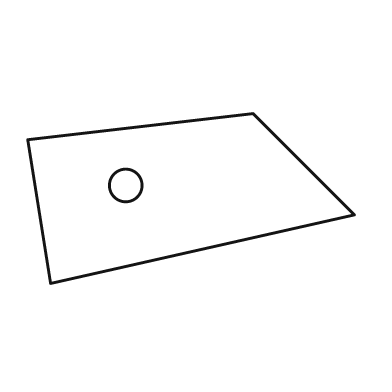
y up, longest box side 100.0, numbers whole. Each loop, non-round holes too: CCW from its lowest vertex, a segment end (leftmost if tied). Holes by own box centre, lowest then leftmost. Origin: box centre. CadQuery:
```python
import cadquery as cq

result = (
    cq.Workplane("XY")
    .moveTo(-43.0, -26.0)
    .lineTo(50.0, -5.0)
    .lineTo(19.0, 26.0)
    .lineTo(-50.0, 18.0)
    .close()
    .moveTo(-20.0, 4.0)
    .circle(5.0)
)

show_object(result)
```